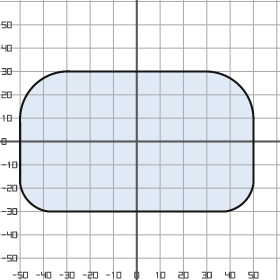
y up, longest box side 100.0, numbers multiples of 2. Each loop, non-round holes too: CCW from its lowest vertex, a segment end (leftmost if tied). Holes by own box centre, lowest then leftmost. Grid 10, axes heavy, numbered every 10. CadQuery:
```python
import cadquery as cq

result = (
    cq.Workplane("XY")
    .moveTo(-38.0, -30.0)
    .lineTo(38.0, -30.0)
    .threePointArc((46.0, -26.0), (50.0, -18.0))
    .lineTo(50.0, 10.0)
    .threePointArc((44.0, 24.0), (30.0, 30.0))
    .lineTo(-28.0, 30.0)
    .threePointArc((-44.0, 24.0), (-50.0, 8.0))
    .lineTo(-50.0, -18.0)
    .threePointArc((-46.0, -26.0), (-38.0, -30.0))
    .close()
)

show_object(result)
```